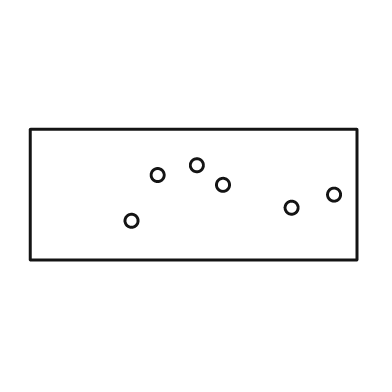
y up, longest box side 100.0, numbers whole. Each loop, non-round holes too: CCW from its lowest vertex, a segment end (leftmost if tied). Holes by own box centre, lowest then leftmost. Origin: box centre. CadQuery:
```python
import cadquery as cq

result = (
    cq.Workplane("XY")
    .moveTo(-50.0, -20.0)
    .lineTo(50.0, -20.0)
    .lineTo(50.0, 20.0)
    .lineTo(-50.0, 20.0)
    .close()
    .moveTo(-19.0, -8.0)
    .circle(2.0)
    .moveTo(30.0, -4.0)
    .circle(2.0)
    .moveTo(43.0, 0.0)
    .circle(2.0)
    .moveTo(9.0, 3.0)
    .circle(2.0)
    .moveTo(-11.0, 6.0)
    .circle(2.0)
    .moveTo(1.0, 9.0)
    .circle(2.0)
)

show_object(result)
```